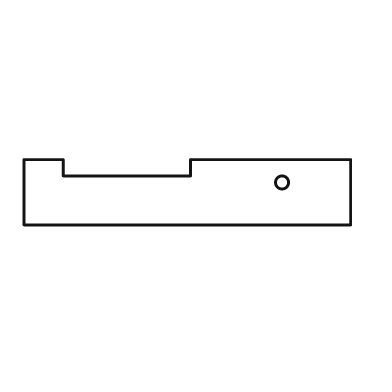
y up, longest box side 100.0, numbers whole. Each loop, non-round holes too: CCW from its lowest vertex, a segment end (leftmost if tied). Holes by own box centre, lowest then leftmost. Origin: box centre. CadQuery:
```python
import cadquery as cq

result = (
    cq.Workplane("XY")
    .moveTo(-50.0, -10.0)
    .lineTo(50.0, -10.0)
    .lineTo(50.0, 10.0)
    .lineTo(1.0, 10.0)
    .lineTo(1.0, 5.0)
    .lineTo(-38.0, 5.0)
    .lineTo(-38.0, 10.0)
    .lineTo(-50.0, 10.0)
    .close()
    .moveTo(29.0, 3.0)
    .circle(2.0)
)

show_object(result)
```